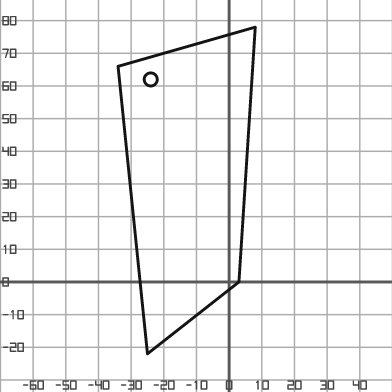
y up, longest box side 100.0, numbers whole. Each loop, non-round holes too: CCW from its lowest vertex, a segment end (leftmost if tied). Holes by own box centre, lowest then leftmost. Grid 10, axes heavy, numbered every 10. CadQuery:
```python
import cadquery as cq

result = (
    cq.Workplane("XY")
    .moveTo(-25.0, -22.0)
    .lineTo(3.0, 0.0)
    .lineTo(8.0, 78.0)
    .lineTo(-34.0, 66.0)
    .close()
    .moveTo(-24.0, 62.0)
    .circle(2.0)
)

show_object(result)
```